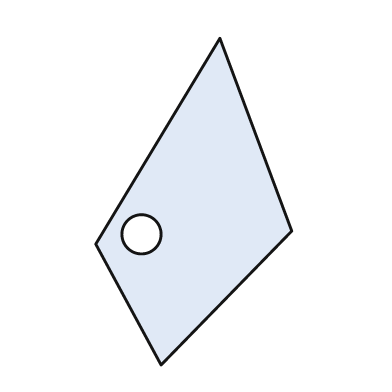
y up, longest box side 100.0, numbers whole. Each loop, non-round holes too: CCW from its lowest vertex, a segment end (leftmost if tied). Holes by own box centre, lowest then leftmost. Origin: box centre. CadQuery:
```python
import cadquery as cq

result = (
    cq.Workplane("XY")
    .moveTo(-10.0, -50.0)
    .lineTo(30.0, -9.0)
    .lineTo(8.0, 50.0)
    .lineTo(-30.0, -13.0)
    .close()
    .moveTo(-16.0, -10.0)
    .circle(6.0)
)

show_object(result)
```